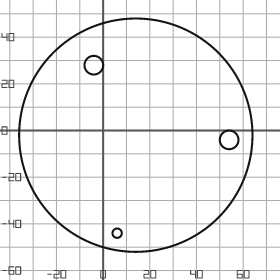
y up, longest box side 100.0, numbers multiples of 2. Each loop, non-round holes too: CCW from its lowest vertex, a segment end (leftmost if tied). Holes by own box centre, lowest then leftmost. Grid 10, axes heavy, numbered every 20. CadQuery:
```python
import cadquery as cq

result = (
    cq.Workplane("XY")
    .moveTo(14.0, -2.0)
    .circle(50.0)
    .moveTo(6.0, -44.0)
    .circle(2.0)
    .moveTo(54.0, -4.0)
    .circle(4.0)
    .moveTo(-4.0, 28.0)
    .circle(4.0)
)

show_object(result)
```